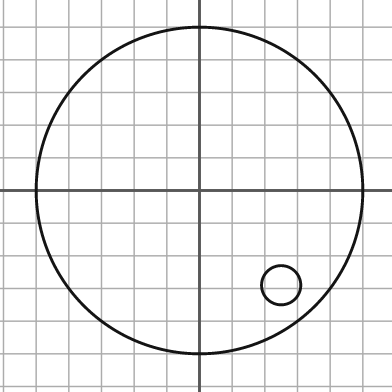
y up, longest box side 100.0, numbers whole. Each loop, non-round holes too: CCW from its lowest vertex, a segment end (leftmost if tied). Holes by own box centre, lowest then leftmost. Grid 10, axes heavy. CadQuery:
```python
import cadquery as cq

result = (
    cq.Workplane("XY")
    .moveTo(0.0, 0.0)
    .circle(50.0)
    .moveTo(25.0, -29.0)
    .circle(6.0)
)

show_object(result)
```